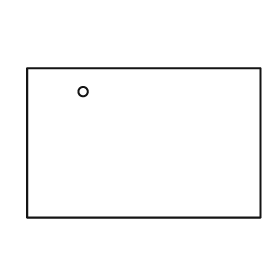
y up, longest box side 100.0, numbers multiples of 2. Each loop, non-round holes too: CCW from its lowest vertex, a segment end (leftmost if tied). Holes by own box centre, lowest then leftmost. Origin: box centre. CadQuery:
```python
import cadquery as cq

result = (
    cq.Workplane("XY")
    .moveTo(-50.0, -32.0)
    .lineTo(50.0, -32.0)
    .lineTo(50.0, 32.0)
    .lineTo(-50.0, 32.0)
    .close()
    .moveTo(-26.0, 22.0)
    .circle(2.0)
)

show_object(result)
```